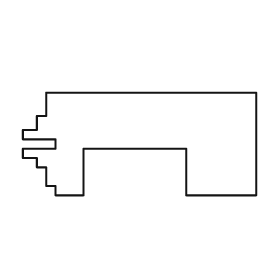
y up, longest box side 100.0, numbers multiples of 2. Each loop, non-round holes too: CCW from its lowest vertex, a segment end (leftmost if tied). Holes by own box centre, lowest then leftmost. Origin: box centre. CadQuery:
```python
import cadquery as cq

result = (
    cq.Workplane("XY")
    .moveTo(-36.0, -22.0)
    .lineTo(-24.0, -22.0)
    .lineTo(-24.0, -2.0)
    .lineTo(20.0, -2.0)
    .lineTo(20.0, -22.0)
    .lineTo(50.0, -22.0)
    .lineTo(50.0, 22.0)
    .lineTo(-40.0, 22.0)
    .lineTo(-40.0, 12.0)
    .lineTo(-44.0, 12.0)
    .lineTo(-44.0, 6.0)
    .lineTo(-50.0, 6.0)
    .lineTo(-50.0, 2.0)
    .lineTo(-36.0, 2.0)
    .lineTo(-36.0, -2.0)
    .lineTo(-50.0, -2.0)
    .lineTo(-50.0, -6.0)
    .lineTo(-44.0, -6.0)
    .lineTo(-44.0, -10.0)
    .lineTo(-40.0, -10.0)
    .lineTo(-40.0, -18.0)
    .lineTo(-36.0, -18.0)
    .close()
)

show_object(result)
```